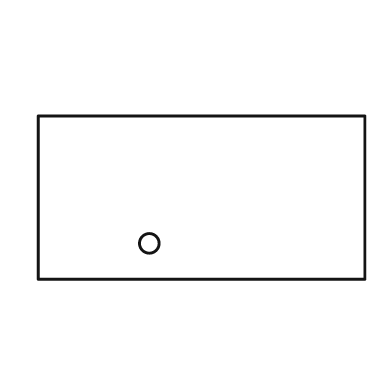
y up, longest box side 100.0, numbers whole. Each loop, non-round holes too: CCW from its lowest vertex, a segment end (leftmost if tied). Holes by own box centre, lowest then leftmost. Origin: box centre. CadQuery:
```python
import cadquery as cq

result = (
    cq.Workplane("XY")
    .moveTo(-50.0, -25.0)
    .lineTo(50.0, -25.0)
    .lineTo(50.0, 25.0)
    .lineTo(-50.0, 25.0)
    .close()
    .moveTo(-16.0, -14.0)
    .circle(3.0)
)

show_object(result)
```